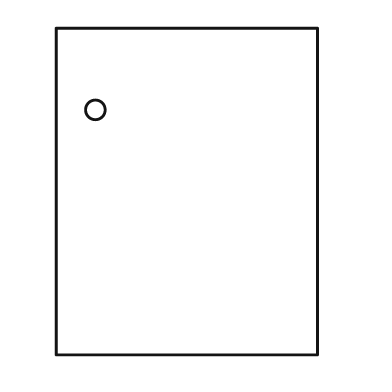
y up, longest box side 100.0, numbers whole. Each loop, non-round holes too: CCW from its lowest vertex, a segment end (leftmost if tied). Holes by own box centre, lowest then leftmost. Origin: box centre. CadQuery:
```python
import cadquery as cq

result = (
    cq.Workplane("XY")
    .moveTo(-40.0, -50.0)
    .lineTo(40.0, -50.0)
    .lineTo(40.0, 50.0)
    .lineTo(-40.0, 50.0)
    .close()
    .moveTo(-28.0, 25.0)
    .circle(3.0)
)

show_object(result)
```